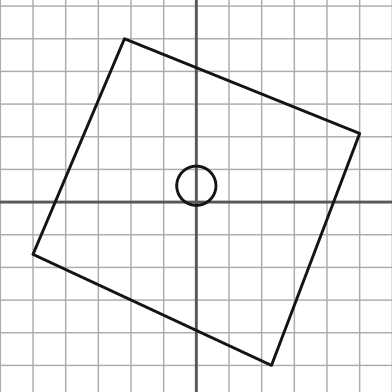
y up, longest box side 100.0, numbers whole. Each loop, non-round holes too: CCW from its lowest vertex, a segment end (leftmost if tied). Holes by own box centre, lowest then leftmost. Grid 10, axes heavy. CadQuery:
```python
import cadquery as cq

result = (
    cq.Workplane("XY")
    .moveTo(23.0, -50.0)
    .lineTo(50.0, 21.0)
    .lineTo(-22.0, 50.0)
    .lineTo(-50.0, -16.0)
    .close()
    .moveTo(0.0, 5.0)
    .circle(6.0)
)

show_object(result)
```